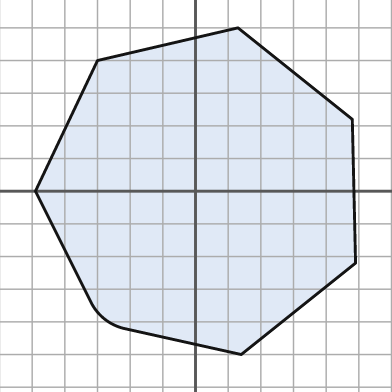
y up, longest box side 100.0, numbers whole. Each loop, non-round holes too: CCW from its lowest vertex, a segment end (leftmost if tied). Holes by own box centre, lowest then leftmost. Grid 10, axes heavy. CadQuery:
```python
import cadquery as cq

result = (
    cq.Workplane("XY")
    .moveTo(14.0, -50.0)
    .lineTo(49.0, -22.0)
    .lineTo(48.0, 22.0)
    .lineTo(13.0, 50.0)
    .lineTo(-30.0, 40.0)
    .lineTo(-49.0, 0.0)
    .lineTo(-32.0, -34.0)
    .threePointArc((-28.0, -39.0), (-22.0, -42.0))
    .close()
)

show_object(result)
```